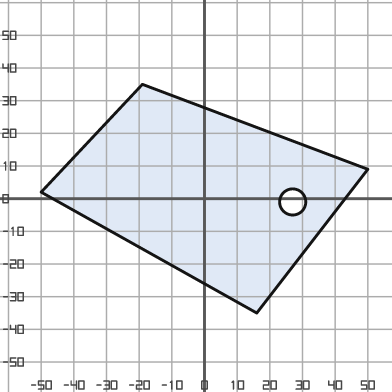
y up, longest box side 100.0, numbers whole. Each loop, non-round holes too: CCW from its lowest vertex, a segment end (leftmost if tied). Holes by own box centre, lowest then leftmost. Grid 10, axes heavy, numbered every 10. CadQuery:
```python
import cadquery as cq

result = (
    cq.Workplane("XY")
    .moveTo(16.0, -35.0)
    .lineTo(50.0, 9.0)
    .lineTo(-19.0, 35.0)
    .lineTo(-50.0, 2.0)
    .close()
    .moveTo(27.0, -1.0)
    .circle(4.0)
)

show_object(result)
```